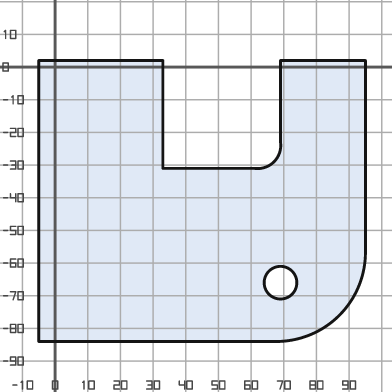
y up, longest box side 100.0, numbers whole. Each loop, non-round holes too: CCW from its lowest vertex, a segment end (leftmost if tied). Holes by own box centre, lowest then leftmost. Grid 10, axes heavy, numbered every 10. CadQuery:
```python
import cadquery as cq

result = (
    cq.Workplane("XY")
    .moveTo(-5.0, -84.0)
    .lineTo(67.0, -84.0)
    .threePointArc((87.0, -76.0), (95.0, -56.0))
    .lineTo(95.0, 2.0)
    .lineTo(69.0, 2.0)
    .lineTo(69.0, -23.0)
    .threePointArc((67.0, -29.0), (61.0, -31.0))
    .lineTo(33.0, -31.0)
    .lineTo(33.0, 2.0)
    .lineTo(-5.0, 2.0)
    .close()
    .moveTo(69.0, -66.0)
    .circle(5.0)
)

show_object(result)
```